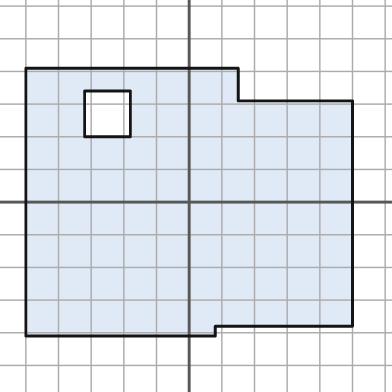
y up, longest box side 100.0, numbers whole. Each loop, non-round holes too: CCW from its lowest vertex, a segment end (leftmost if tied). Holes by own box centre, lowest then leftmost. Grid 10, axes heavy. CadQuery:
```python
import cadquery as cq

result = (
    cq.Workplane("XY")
    .moveTo(-50.0, -41.0)
    .lineTo(8.0, -41.0)
    .lineTo(8.0, -38.0)
    .lineTo(50.0, -38.0)
    .lineTo(50.0, 31.0)
    .lineTo(15.0, 31.0)
    .lineTo(15.0, 41.0)
    .lineTo(-50.0, 41.0)
    .close()
    .moveTo(-32.0, 20.0)
    .lineTo(-18.0, 20.0)
    .lineTo(-18.0, 34.0)
    .lineTo(-32.0, 34.0)
    .close()
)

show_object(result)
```